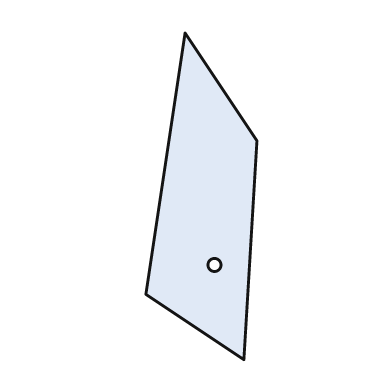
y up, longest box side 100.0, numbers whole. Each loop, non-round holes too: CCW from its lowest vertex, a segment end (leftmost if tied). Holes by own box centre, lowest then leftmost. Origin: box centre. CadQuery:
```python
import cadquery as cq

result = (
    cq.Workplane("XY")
    .moveTo(13.0, -50.0)
    .lineTo(17.0, 17.0)
    .lineTo(-5.0, 50.0)
    .lineTo(-17.0, -30.0)
    .close()
    .moveTo(4.0, -21.0)
    .circle(2.0)
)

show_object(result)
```